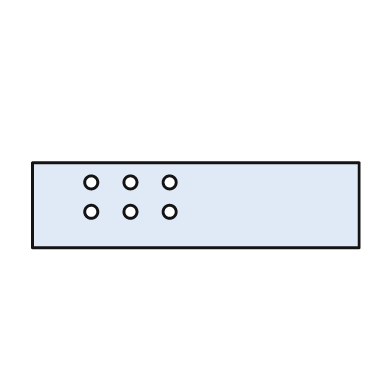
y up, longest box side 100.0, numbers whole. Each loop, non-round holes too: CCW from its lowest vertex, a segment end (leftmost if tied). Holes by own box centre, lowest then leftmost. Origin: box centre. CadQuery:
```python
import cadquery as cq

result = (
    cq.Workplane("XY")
    .moveTo(-50.0, -13.0)
    .lineTo(50.0, -13.0)
    .lineTo(50.0, 13.0)
    .lineTo(-50.0, 13.0)
    .close()
    .moveTo(-32.0, -2.0)
    .circle(2.0)
    .moveTo(-20.0, -2.0)
    .circle(2.0)
    .moveTo(-8.0, -2.0)
    .circle(2.0)
    .moveTo(-32.0, 7.0)
    .circle(2.0)
    .moveTo(-20.0, 7.0)
    .circle(2.0)
    .moveTo(-8.0, 7.0)
    .circle(2.0)
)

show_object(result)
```